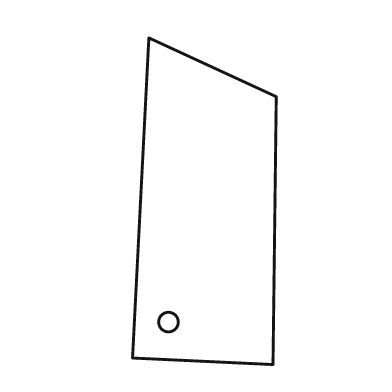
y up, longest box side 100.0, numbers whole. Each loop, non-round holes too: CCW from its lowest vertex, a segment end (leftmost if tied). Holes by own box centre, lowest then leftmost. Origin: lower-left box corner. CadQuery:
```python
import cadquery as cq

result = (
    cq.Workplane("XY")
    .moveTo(43.0, 0.0)
    .lineTo(44.0, 82.0)
    .lineTo(5.0, 100.0)
    .lineTo(0.0, 2.0)
    .close()
    .moveTo(11.0, 13.0)
    .circle(3.0)
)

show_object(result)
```